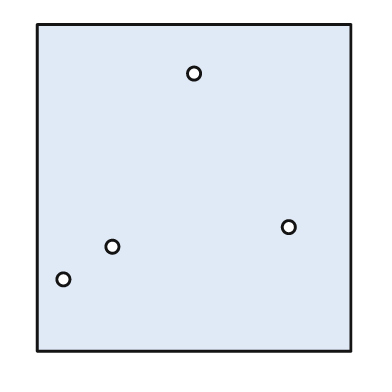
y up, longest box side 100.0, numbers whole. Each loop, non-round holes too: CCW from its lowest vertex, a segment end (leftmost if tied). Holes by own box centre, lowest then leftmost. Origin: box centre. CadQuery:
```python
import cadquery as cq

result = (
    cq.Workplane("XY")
    .moveTo(-48.0, -50.0)
    .lineTo(48.0, -50.0)
    .lineTo(48.0, 50.0)
    .lineTo(-48.0, 50.0)
    .close()
    .moveTo(-40.0, -28.0)
    .circle(2.0)
    .moveTo(-25.0, -18.0)
    .circle(2.0)
    .moveTo(29.0, -12.0)
    .circle(2.0)
    .moveTo(0.0, 35.0)
    .circle(2.0)
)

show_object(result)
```